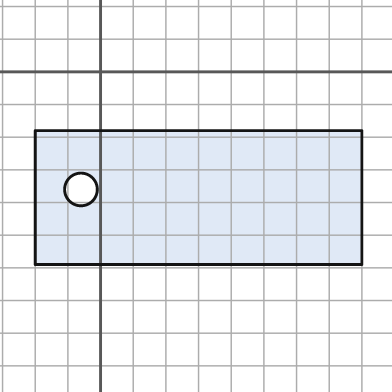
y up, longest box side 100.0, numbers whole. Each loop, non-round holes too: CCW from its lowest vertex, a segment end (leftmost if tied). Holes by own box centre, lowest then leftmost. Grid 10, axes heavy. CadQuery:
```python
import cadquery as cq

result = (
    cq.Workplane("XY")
    .moveTo(-20.0, -59.0)
    .lineTo(80.0, -59.0)
    .lineTo(80.0, -18.0)
    .lineTo(-20.0, -18.0)
    .close()
    .moveTo(-6.0, -36.0)
    .circle(5.0)
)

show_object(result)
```